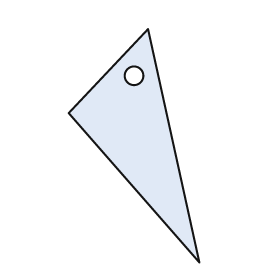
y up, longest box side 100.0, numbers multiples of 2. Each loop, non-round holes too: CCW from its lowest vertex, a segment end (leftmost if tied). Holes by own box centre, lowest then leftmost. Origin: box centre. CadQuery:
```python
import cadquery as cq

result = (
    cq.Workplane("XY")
    .moveTo(28.0, -50.0)
    .lineTo(6.0, 50.0)
    .lineTo(-28.0, 14.0)
    .close()
    .moveTo(0.0, 30.0)
    .circle(4.0)
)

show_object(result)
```